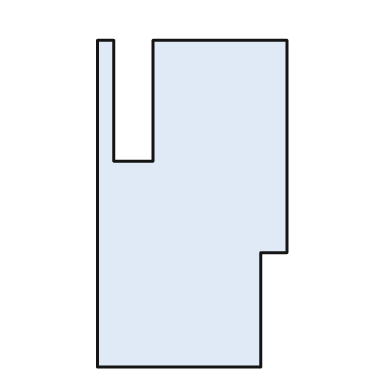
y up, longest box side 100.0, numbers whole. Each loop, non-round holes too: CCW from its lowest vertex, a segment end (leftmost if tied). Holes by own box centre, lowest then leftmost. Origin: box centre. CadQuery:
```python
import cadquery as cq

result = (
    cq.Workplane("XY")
    .moveTo(-29.0, -50.0)
    .lineTo(21.0, -50.0)
    .lineTo(21.0, -15.0)
    .lineTo(29.0, -15.0)
    .lineTo(29.0, 50.0)
    .lineTo(-12.0, 50.0)
    .lineTo(-12.0, 13.0)
    .lineTo(-24.0, 13.0)
    .lineTo(-24.0, 50.0)
    .lineTo(-29.0, 50.0)
    .close()
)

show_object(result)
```